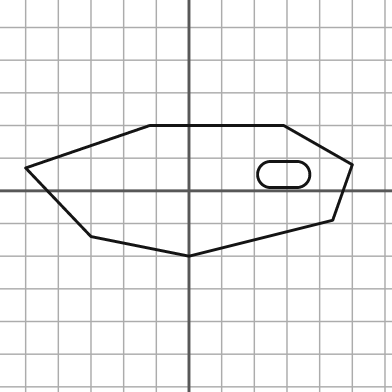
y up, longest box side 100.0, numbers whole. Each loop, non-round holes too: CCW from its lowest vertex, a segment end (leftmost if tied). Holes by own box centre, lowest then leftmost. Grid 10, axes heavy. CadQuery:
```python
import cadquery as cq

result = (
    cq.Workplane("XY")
    .moveTo(0.0, -20.0)
    .lineTo(44.0, -9.0)
    .lineTo(50.0, 8.0)
    .lineTo(29.0, 20.0)
    .lineTo(-12.0, 20.0)
    .lineTo(-50.0, 7.0)
    .lineTo(-30.0, -14.0)
    .close()
    .moveTo(25.0, 1.0)
    .lineTo(33.0, 1.0)
    .threePointArc((37.0, 5.0), (33.0, 9.0))
    .lineTo(25.0, 9.0)
    .threePointArc((21.0, 5.0), (25.0, 1.0))
    .close()
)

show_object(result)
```